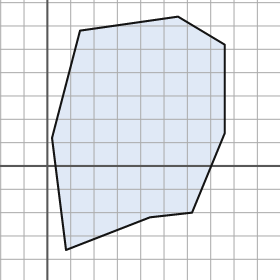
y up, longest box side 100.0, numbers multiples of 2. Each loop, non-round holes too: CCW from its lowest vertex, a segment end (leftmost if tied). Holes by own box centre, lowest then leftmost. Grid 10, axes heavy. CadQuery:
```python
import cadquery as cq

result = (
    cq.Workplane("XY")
    .moveTo(8.0, -36.0)
    .lineTo(44.0, -22.0)
    .lineTo(62.0, -20.0)
    .lineTo(76.0, 14.0)
    .lineTo(76.0, 52.0)
    .lineTo(56.0, 64.0)
    .lineTo(14.0, 58.0)
    .lineTo(2.0, 12.0)
    .close()
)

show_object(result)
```